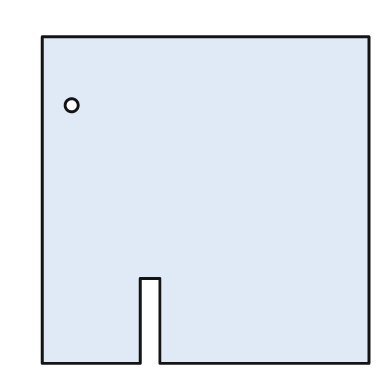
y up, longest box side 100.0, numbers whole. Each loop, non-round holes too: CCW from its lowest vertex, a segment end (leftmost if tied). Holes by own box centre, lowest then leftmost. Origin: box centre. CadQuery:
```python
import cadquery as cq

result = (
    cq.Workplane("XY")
    .moveTo(-50.0, -50.0)
    .lineTo(-20.0, -50.0)
    .lineTo(-20.0, -24.0)
    .lineTo(-14.0, -24.0)
    .lineTo(-14.0, -50.0)
    .lineTo(50.0, -50.0)
    .lineTo(50.0, 50.0)
    .lineTo(-50.0, 50.0)
    .close()
    .moveTo(-41.0, 29.0)
    .circle(2.0)
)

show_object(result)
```